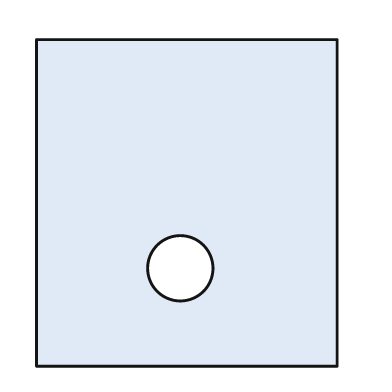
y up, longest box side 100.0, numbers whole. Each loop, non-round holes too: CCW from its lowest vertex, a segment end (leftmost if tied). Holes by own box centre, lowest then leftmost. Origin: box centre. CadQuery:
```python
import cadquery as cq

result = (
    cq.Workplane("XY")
    .moveTo(-46.0, -50.0)
    .lineTo(46.0, -50.0)
    .lineTo(46.0, 50.0)
    .lineTo(-46.0, 50.0)
    .close()
    .moveTo(-2.0, -20.0)
    .circle(10.0)
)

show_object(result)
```